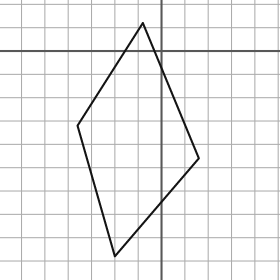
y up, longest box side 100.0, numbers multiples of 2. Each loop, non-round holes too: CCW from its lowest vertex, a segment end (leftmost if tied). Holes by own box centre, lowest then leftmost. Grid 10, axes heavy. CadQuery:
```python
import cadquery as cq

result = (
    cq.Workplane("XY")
    .moveTo(-20.0, -88.0)
    .lineTo(16.0, -46.0)
    .lineTo(-8.0, 12.0)
    .lineTo(-36.0, -32.0)
    .close()
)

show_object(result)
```